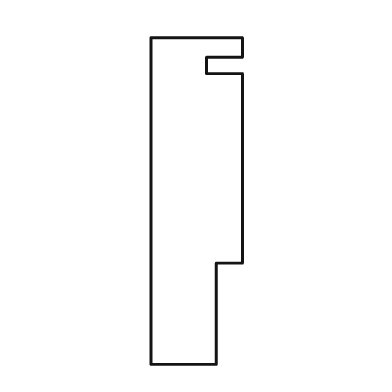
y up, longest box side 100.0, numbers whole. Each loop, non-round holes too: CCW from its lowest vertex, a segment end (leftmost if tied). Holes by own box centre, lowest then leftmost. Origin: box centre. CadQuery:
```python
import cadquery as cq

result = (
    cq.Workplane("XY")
    .moveTo(-14.0, -50.0)
    .lineTo(6.0, -50.0)
    .lineTo(6.0, -19.0)
    .lineTo(14.0, -19.0)
    .lineTo(14.0, 39.0)
    .lineTo(3.0, 39.0)
    .lineTo(3.0, 44.0)
    .lineTo(14.0, 44.0)
    .lineTo(14.0, 50.0)
    .lineTo(-14.0, 50.0)
    .close()
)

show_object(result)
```